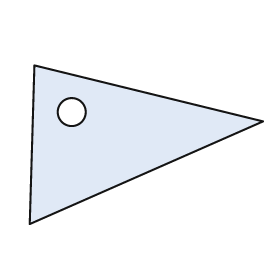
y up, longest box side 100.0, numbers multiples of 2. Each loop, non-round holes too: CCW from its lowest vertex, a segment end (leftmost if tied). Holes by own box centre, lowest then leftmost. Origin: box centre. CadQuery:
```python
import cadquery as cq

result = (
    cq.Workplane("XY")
    .moveTo(-50.0, -34.0)
    .lineTo(50.0, 10.0)
    .lineTo(-48.0, 34.0)
    .close()
    .moveTo(-32.0, 14.0)
    .circle(6.0)
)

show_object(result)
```